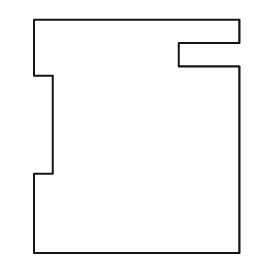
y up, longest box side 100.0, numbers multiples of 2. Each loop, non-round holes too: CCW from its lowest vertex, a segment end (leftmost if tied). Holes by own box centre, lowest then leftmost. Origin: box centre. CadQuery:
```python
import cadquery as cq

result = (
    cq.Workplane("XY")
    .moveTo(-44.0, -50.0)
    .lineTo(44.0, -50.0)
    .lineTo(44.0, 30.0)
    .lineTo(18.0, 30.0)
    .lineTo(18.0, 40.0)
    .lineTo(44.0, 40.0)
    .lineTo(44.0, 50.0)
    .lineTo(-44.0, 50.0)
    .lineTo(-44.0, 26.0)
    .lineTo(-36.0, 26.0)
    .lineTo(-36.0, -16.0)
    .lineTo(-44.0, -16.0)
    .close()
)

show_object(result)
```